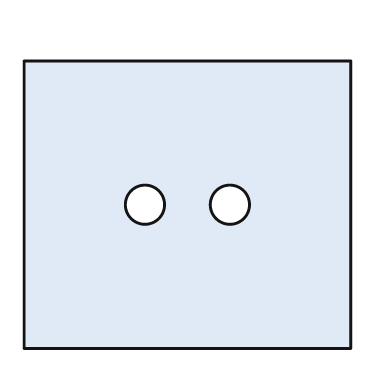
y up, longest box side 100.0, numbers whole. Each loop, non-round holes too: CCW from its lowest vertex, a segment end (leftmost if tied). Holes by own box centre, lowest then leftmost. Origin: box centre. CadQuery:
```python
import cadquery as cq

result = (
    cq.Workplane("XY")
    .moveTo(-50.0, -44.0)
    .lineTo(50.0, -44.0)
    .lineTo(50.0, 44.0)
    .lineTo(-50.0, 44.0)
    .close()
    .moveTo(-13.0, 0.0)
    .circle(6.0)
    .moveTo(13.0, 0.0)
    .circle(6.0)
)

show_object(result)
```